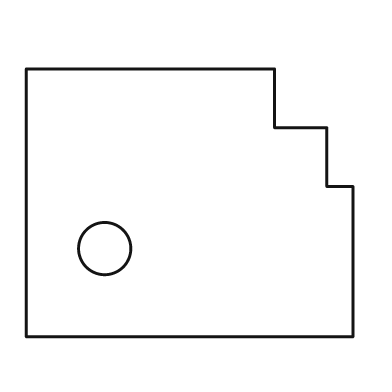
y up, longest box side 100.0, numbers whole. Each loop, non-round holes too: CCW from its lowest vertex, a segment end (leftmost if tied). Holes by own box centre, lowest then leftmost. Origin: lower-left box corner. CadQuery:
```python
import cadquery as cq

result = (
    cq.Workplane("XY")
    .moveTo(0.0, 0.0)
    .lineTo(100.0, 0.0)
    .lineTo(100.0, 46.0)
    .lineTo(92.0, 46.0)
    .lineTo(92.0, 64.0)
    .lineTo(76.0, 64.0)
    .lineTo(76.0, 82.0)
    .lineTo(0.0, 82.0)
    .close()
    .moveTo(24.0, 27.0)
    .circle(8.0)
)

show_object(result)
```